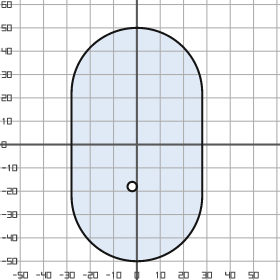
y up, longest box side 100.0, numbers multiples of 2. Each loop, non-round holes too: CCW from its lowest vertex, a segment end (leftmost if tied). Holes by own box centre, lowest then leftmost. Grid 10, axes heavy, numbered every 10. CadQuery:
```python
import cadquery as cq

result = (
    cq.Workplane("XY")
    .moveTo(-28.0, -22.0)
    .threePointArc((0.0, -50.0), (28.0, -22.0))
    .lineTo(28.0, 22.0)
    .threePointArc((0.0, 50.0), (-28.0, 22.0))
    .close()
    .moveTo(-2.0, -18.0)
    .circle(2.0)
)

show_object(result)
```